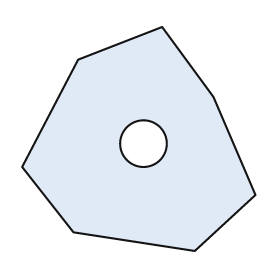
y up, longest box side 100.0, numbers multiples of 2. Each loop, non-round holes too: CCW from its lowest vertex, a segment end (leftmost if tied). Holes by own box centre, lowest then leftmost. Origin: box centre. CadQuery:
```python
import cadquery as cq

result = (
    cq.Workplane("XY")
    .moveTo(24.0, -48.0)
    .lineTo(50.0, -24.0)
    .lineTo(32.0, 18.0)
    .lineTo(10.0, 48.0)
    .lineTo(-26.0, 34.0)
    .lineTo(-50.0, -12.0)
    .lineTo(-28.0, -40.0)
    .close()
    .moveTo(2.0, -2.0)
    .circle(10.0)
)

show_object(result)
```